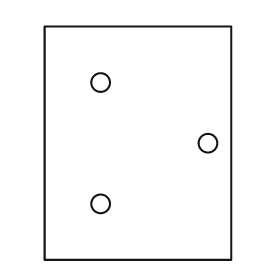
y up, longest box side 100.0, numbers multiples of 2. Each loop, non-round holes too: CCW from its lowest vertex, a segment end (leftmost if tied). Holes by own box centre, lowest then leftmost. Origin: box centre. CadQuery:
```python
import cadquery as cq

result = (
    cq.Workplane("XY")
    .moveTo(-40.0, -50.0)
    .lineTo(40.0, -50.0)
    .lineTo(40.0, 50.0)
    .lineTo(-40.0, 50.0)
    .close()
    .moveTo(-16.0, -26.0)
    .circle(4.0)
    .moveTo(30.0, 0.0)
    .circle(4.0)
    .moveTo(-16.0, 26.0)
    .circle(4.0)
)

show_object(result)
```